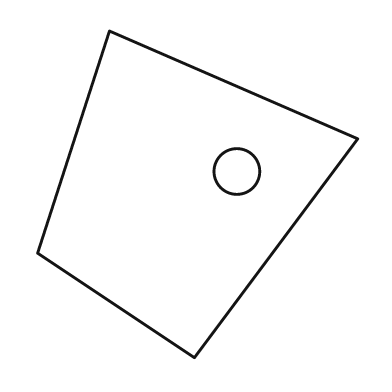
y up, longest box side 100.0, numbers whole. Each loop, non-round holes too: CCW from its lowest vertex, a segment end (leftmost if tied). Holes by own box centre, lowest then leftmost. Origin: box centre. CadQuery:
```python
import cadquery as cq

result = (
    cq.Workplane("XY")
    .moveTo(-1.0, -50.0)
    .lineTo(49.0, 17.0)
    .lineTo(-27.0, 50.0)
    .lineTo(-49.0, -18.0)
    .close()
    .moveTo(12.0, 7.0)
    .circle(7.0)
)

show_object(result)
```